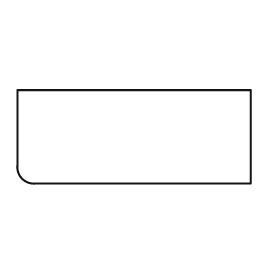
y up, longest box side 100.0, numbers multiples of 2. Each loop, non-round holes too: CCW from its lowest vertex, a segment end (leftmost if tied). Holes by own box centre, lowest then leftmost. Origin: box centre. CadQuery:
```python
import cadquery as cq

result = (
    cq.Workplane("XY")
    .moveTo(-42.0, -20.0)
    .lineTo(50.0, -20.0)
    .lineTo(50.0, 20.0)
    .lineTo(-50.0, 20.0)
    .lineTo(-50.0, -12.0)
    .threePointArc((-48.0, -18.0), (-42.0, -20.0))
    .close()
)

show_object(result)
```